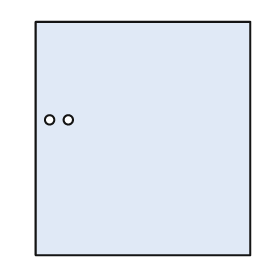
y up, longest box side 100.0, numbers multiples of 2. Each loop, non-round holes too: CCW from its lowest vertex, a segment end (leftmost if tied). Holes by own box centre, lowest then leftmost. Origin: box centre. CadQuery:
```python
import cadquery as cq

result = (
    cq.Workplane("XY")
    .moveTo(-46.0, -50.0)
    .lineTo(46.0, -50.0)
    .lineTo(46.0, 50.0)
    .lineTo(-46.0, 50.0)
    .close()
    .moveTo(-40.0, 8.0)
    .circle(2.0)
    .moveTo(-32.0, 8.0)
    .circle(2.0)
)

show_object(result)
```